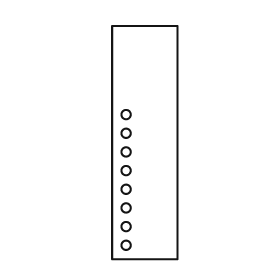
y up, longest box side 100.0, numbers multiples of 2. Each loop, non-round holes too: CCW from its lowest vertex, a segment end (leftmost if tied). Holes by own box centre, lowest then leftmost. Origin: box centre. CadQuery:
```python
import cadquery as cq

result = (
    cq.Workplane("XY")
    .moveTo(-14.0, -50.0)
    .lineTo(14.0, -50.0)
    .lineTo(14.0, 50.0)
    .lineTo(-14.0, 50.0)
    .close()
    .moveTo(-8.0, -44.0)
    .circle(2.0)
    .moveTo(-8.0, -36.0)
    .circle(2.0)
    .moveTo(-8.0, -28.0)
    .circle(2.0)
    .moveTo(-8.0, -20.0)
    .circle(2.0)
    .moveTo(-8.0, -12.0)
    .circle(2.0)
    .moveTo(-8.0, -4.0)
    .circle(2.0)
    .moveTo(-8.0, 4.0)
    .circle(2.0)
    .moveTo(-8.0, 12.0)
    .circle(2.0)
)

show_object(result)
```